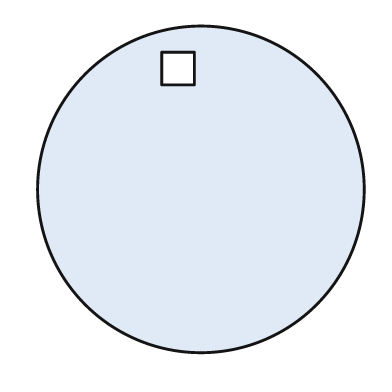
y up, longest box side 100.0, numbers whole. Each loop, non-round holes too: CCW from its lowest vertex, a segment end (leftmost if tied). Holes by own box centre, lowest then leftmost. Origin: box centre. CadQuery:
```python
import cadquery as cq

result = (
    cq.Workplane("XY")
    .moveTo(0.0, 0.0)
    .circle(50.0)
    .moveTo(-12.0, 32.0)
    .lineTo(-2.0, 32.0)
    .lineTo(-2.0, 42.0)
    .lineTo(-12.0, 42.0)
    .close()
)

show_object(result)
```